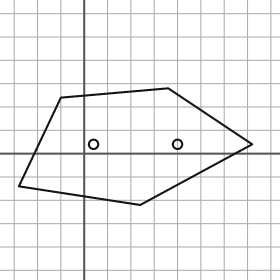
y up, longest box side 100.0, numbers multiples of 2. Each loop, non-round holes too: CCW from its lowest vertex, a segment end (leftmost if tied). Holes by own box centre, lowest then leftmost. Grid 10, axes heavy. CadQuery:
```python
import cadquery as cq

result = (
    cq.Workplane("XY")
    .moveTo(24.0, -22.0)
    .lineTo(72.0, 4.0)
    .lineTo(36.0, 28.0)
    .lineTo(-10.0, 24.0)
    .lineTo(-28.0, -14.0)
    .close()
    .moveTo(4.0, 4.0)
    .circle(2.0)
    .moveTo(40.0, 4.0)
    .circle(2.0)
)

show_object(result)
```